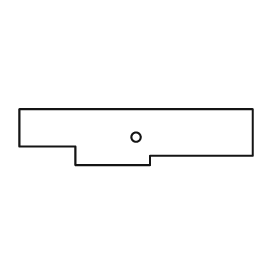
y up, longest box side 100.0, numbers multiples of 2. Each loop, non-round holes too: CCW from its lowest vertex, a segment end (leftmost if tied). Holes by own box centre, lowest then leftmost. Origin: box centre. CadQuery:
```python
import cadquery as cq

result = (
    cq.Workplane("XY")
    .moveTo(-26.0, -12.0)
    .lineTo(6.0, -12.0)
    .lineTo(6.0, -8.0)
    .lineTo(50.0, -8.0)
    .lineTo(50.0, 12.0)
    .lineTo(-50.0, 12.0)
    .lineTo(-50.0, -4.0)
    .lineTo(-26.0, -4.0)
    .close()
    .moveTo(0.0, 0.0)
    .circle(2.0)
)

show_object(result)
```